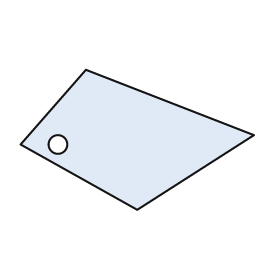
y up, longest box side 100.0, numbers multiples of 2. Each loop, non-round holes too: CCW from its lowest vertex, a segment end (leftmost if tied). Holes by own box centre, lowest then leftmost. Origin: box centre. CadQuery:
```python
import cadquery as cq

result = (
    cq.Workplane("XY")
    .moveTo(0.0, -30.0)
    .lineTo(50.0, 2.0)
    .lineTo(-22.0, 30.0)
    .lineTo(-50.0, -2.0)
    .close()
    .moveTo(-34.0, -2.0)
    .circle(4.0)
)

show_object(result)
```